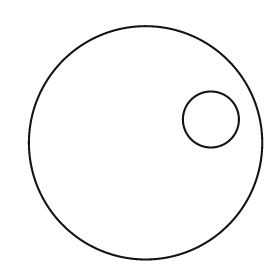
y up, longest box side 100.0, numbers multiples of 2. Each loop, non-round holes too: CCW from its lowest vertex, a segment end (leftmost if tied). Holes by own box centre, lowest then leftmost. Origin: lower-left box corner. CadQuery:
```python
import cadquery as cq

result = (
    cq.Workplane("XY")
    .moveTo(50.0, 50.0)
    .circle(50.0)
    .moveTo(78.0, 60.0)
    .circle(12.0)
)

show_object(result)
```